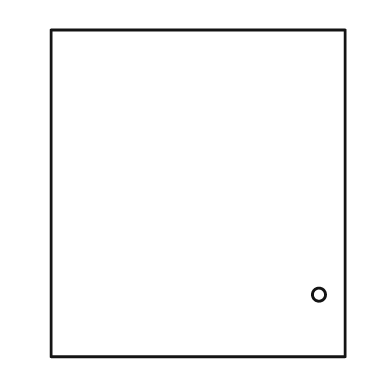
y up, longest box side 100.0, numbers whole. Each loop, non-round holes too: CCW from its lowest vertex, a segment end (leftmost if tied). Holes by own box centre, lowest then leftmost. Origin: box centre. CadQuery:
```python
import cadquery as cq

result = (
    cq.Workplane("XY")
    .moveTo(-45.0, -50.0)
    .lineTo(45.0, -50.0)
    .lineTo(45.0, 50.0)
    .lineTo(-45.0, 50.0)
    .close()
    .moveTo(37.0, -31.0)
    .circle(2.0)
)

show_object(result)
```